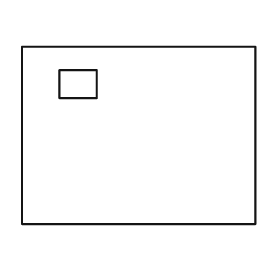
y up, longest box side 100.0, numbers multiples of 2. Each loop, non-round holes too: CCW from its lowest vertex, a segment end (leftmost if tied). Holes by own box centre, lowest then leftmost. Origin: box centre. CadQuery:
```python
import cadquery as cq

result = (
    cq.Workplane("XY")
    .moveTo(-50.0, -38.0)
    .lineTo(50.0, -38.0)
    .lineTo(50.0, 38.0)
    .lineTo(-50.0, 38.0)
    .close()
    .moveTo(-34.0, 16.0)
    .lineTo(-18.0, 16.0)
    .lineTo(-18.0, 28.0)
    .lineTo(-34.0, 28.0)
    .close()
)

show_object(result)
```